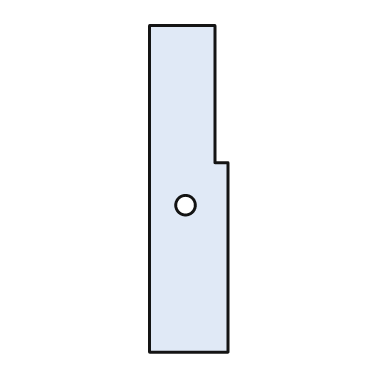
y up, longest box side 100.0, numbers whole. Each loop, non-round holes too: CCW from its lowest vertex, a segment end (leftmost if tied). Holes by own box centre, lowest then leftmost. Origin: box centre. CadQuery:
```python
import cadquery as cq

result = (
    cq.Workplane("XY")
    .moveTo(-12.0, -50.0)
    .lineTo(12.0, -50.0)
    .lineTo(12.0, 8.0)
    .lineTo(8.0, 8.0)
    .lineTo(8.0, 50.0)
    .lineTo(-12.0, 50.0)
    .close()
    .moveTo(-1.0, -5.0)
    .circle(3.0)
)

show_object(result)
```